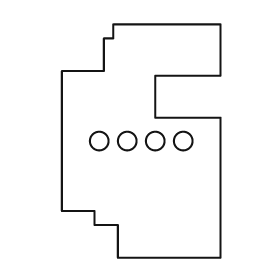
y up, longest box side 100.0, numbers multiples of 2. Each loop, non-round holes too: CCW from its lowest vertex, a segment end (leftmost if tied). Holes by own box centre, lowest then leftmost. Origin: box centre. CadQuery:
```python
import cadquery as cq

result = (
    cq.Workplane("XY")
    .moveTo(-10.0, -50.0)
    .lineTo(34.0, -50.0)
    .lineTo(34.0, 10.0)
    .lineTo(6.0, 10.0)
    .lineTo(6.0, 28.0)
    .lineTo(34.0, 28.0)
    .lineTo(34.0, 50.0)
    .lineTo(-12.0, 50.0)
    .lineTo(-12.0, 44.0)
    .lineTo(-16.0, 44.0)
    .lineTo(-16.0, 30.0)
    .lineTo(-34.0, 30.0)
    .lineTo(-34.0, -30.0)
    .lineTo(-20.0, -30.0)
    .lineTo(-20.0, -36.0)
    .lineTo(-10.0, -36.0)
    .close()
    .moveTo(-18.0, 0.0)
    .circle(4.0)
    .moveTo(-6.0, 0.0)
    .circle(4.0)
    .moveTo(6.0, 0.0)
    .circle(4.0)
    .moveTo(18.0, 0.0)
    .circle(4.0)
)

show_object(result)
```